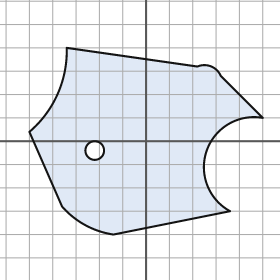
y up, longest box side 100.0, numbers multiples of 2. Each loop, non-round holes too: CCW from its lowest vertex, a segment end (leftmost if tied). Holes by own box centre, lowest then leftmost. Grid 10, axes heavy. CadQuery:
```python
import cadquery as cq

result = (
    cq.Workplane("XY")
    .moveTo(-14.0, -40.0)
    .lineTo(36.0, -30.0)
    .threePointArc((26.0, -4.0), (50.0, 10.0))
    .lineTo(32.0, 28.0)
    .threePointArc((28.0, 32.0), (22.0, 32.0))
    .lineTo(-34.0, 40.0)
    .threePointArc((-38.0, 20.0), (-50.0, 4.0))
    .lineTo(-36.0, -28.0)
    .threePointArc((-26.0, -36.0), (-14.0, -40.0))
    .close()
    .moveTo(-22.0, -4.0)
    .circle(4.0)
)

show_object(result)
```